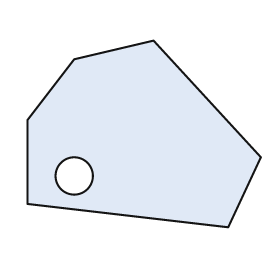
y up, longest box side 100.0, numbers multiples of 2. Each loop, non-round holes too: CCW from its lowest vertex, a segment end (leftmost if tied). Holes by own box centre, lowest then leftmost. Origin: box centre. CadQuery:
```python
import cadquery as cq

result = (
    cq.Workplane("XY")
    .moveTo(36.0, -40.0)
    .lineTo(50.0, -10.0)
    .lineTo(4.0, 40.0)
    .lineTo(-30.0, 32.0)
    .lineTo(-50.0, 6.0)
    .lineTo(-50.0, -30.0)
    .close()
    .moveTo(-30.0, -18.0)
    .circle(8.0)
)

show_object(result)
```